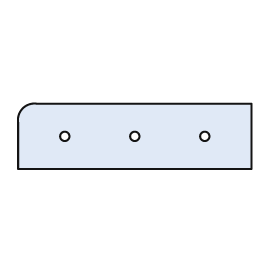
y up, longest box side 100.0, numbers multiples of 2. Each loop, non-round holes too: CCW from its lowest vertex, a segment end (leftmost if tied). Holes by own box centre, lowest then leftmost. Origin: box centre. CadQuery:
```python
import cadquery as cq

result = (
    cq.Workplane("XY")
    .moveTo(-50.0, -14.0)
    .lineTo(50.0, -14.0)
    .lineTo(50.0, 14.0)
    .lineTo(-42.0, 14.0)
    .threePointArc((-48.0, 12.0), (-50.0, 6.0))
    .close()
    .moveTo(-30.0, 0.0)
    .circle(2.0)
    .moveTo(0.0, 0.0)
    .circle(2.0)
    .moveTo(30.0, 0.0)
    .circle(2.0)
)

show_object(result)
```